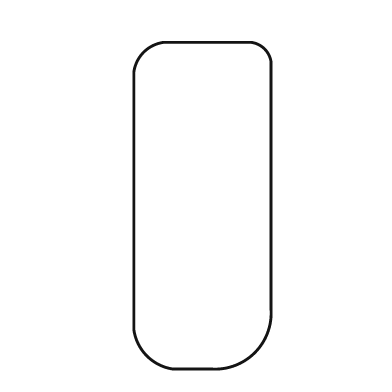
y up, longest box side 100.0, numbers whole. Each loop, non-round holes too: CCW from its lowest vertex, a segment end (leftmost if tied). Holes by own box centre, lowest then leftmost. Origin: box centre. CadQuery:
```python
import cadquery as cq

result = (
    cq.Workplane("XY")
    .moveTo(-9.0, -50.0)
    .lineTo(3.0, -50.0)
    .threePointArc((16.0, -45.0), (21.0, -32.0))
    .lineTo(21.0, 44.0)
    .threePointArc((19.0, 48.0), (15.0, 50.0))
    .lineTo(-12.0, 50.0)
    .threePointArc((-18.0, 47.0), (-21.0, 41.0))
    .lineTo(-21.0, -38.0)
    .threePointArc((-17.0, -46.0), (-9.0, -50.0))
    .close()
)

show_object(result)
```